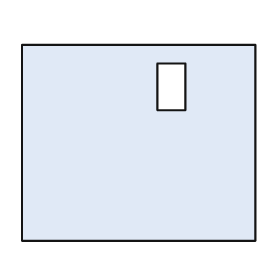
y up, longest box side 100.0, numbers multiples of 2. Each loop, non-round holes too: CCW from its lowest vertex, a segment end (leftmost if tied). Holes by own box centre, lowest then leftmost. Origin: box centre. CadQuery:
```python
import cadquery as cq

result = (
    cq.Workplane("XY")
    .moveTo(-50.0, -42.0)
    .lineTo(50.0, -42.0)
    .lineTo(50.0, 42.0)
    .lineTo(-50.0, 42.0)
    .close()
    .moveTo(8.0, 14.0)
    .lineTo(20.0, 14.0)
    .lineTo(20.0, 34.0)
    .lineTo(8.0, 34.0)
    .close()
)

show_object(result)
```